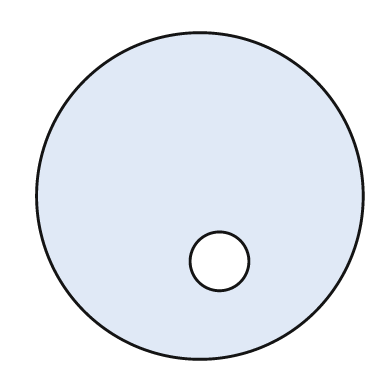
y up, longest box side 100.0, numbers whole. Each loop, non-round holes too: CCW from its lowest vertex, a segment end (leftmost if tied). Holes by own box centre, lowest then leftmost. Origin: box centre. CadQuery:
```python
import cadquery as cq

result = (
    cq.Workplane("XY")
    .moveTo(0.0, 0.0)
    .circle(50.0)
    .moveTo(6.0, -20.0)
    .circle(9.0)
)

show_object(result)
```